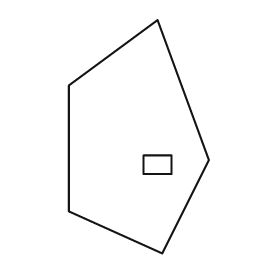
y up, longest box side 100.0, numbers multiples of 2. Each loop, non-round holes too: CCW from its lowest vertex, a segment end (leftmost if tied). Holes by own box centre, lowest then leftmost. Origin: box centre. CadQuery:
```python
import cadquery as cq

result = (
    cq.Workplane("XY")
    .moveTo(10.0, -50.0)
    .lineTo(30.0, -10.0)
    .lineTo(8.0, 50.0)
    .lineTo(-30.0, 22.0)
    .lineTo(-30.0, -32.0)
    .close()
    .moveTo(2.0, -16.0)
    .lineTo(14.0, -16.0)
    .lineTo(14.0, -8.0)
    .lineTo(2.0, -8.0)
    .close()
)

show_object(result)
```